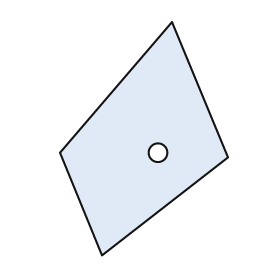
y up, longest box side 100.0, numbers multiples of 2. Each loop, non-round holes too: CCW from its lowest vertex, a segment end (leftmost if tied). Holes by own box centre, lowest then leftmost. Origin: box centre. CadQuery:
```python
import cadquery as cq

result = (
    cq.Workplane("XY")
    .moveTo(-18.0, -50.0)
    .lineTo(36.0, -8.0)
    .lineTo(12.0, 50.0)
    .lineTo(-36.0, -6.0)
    .close()
    .moveTo(6.0, -6.0)
    .circle(4.0)
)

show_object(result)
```